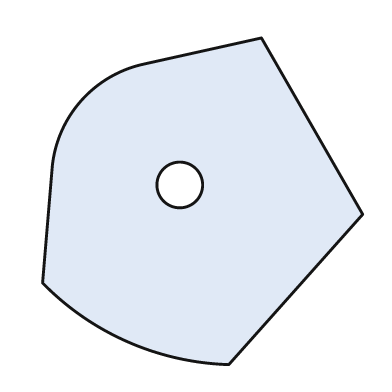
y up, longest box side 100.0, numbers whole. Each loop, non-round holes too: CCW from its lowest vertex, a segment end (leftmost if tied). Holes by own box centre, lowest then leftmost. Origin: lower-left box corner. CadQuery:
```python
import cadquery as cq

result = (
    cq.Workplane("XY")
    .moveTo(57.0, 0.0)
    .lineTo(98.0, 46.0)
    .lineTo(67.0, 100.0)
    .lineTo(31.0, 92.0)
    .threePointArc((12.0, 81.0), (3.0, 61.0))
    .lineTo(0.0, 25.0)
    .threePointArc((26.0, 7.0), (57.0, 0.0))
    .close()
    .moveTo(42.0, 55.0)
    .circle(7.0)
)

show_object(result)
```